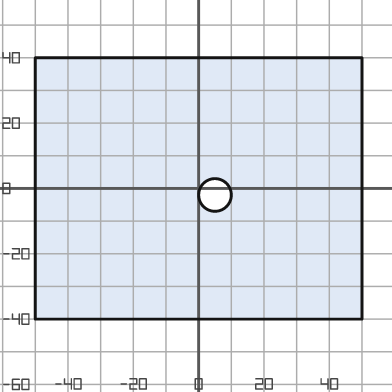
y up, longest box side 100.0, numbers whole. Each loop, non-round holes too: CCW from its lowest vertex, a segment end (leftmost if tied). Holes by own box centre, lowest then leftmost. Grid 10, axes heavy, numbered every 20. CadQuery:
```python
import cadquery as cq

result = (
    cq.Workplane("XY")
    .moveTo(-50.0, -40.0)
    .lineTo(50.0, -40.0)
    .lineTo(50.0, 40.0)
    .lineTo(-50.0, 40.0)
    .close()
    .moveTo(5.0, -2.0)
    .circle(5.0)
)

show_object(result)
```